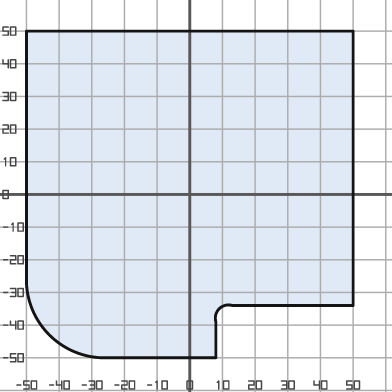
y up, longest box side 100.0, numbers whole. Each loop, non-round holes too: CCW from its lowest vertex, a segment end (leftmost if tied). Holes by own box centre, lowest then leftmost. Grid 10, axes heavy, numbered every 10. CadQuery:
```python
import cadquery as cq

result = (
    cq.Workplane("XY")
    .moveTo(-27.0, -50.0)
    .lineTo(8.0, -50.0)
    .lineTo(8.0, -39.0)
    .threePointArc((9.0, -35.0), (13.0, -34.0))
    .lineTo(50.0, -34.0)
    .lineTo(50.0, 50.0)
    .lineTo(-50.0, 50.0)
    .lineTo(-50.0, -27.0)
    .threePointArc((-43.0, -43.0), (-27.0, -50.0))
    .close()
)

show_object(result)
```